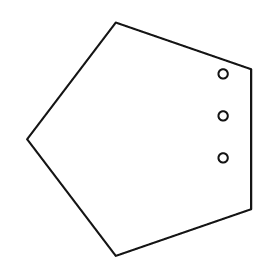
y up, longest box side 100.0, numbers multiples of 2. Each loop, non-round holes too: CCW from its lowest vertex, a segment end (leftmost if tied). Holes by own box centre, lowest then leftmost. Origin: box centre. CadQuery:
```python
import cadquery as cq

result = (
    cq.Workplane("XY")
    .moveTo(-10.0, -50.0)
    .lineTo(48.0, -30.0)
    .lineTo(48.0, 30.0)
    .lineTo(-10.0, 50.0)
    .lineTo(-48.0, 0.0)
    .close()
    .moveTo(36.0, -8.0)
    .circle(2.0)
    .moveTo(36.0, 10.0)
    .circle(2.0)
    .moveTo(36.0, 28.0)
    .circle(2.0)
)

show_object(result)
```